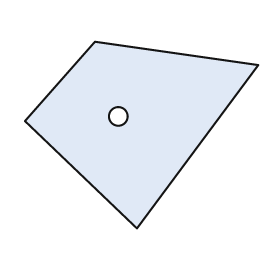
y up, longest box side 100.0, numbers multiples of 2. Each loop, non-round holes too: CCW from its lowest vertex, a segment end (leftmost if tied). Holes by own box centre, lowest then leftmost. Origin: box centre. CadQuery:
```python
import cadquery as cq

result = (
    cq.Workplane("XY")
    .moveTo(-2.0, -40.0)
    .lineTo(50.0, 30.0)
    .lineTo(-20.0, 40.0)
    .lineTo(-50.0, 6.0)
    .close()
    .moveTo(-10.0, 8.0)
    .circle(4.0)
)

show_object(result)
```